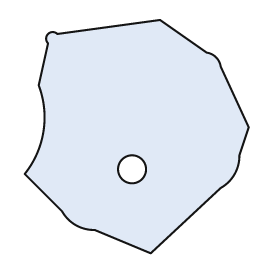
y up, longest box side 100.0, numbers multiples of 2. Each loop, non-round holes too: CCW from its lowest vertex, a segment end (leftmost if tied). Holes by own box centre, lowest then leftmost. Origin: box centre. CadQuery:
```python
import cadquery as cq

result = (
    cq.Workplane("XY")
    .moveTo(6.0, -50.0)
    .lineTo(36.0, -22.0)
    .threePointArc((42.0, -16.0), (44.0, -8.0))
    .lineTo(48.0, 4.0)
    .lineTo(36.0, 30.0)
    .threePointArc((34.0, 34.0), (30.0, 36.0))
    .lineTo(10.0, 50.0)
    .lineTo(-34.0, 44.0)
    .threePointArc((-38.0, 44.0), (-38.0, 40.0))
    .lineTo(-42.0, 22.0)
    .threePointArc((-40.0, 2.0), (-48.0, -16.0))
    .lineTo(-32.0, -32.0)
    .threePointArc((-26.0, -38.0), (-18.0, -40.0))
    .close()
    .moveTo(-2.0, -14.0)
    .circle(6.0)
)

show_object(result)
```